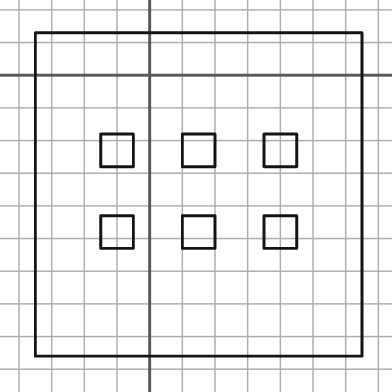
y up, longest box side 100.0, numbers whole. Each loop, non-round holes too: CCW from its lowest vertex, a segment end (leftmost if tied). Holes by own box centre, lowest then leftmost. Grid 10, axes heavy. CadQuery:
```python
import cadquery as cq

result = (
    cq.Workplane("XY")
    .moveTo(-35.0, -86.0)
    .lineTo(65.0, -86.0)
    .lineTo(65.0, 13.0)
    .lineTo(-35.0, 13.0)
    .close()
    .moveTo(-15.0, -53.0)
    .lineTo(-5.0, -53.0)
    .lineTo(-5.0, -43.0)
    .lineTo(-15.0, -43.0)
    .close()
    .moveTo(10.0, -53.0)
    .lineTo(20.0, -53.0)
    .lineTo(20.0, -43.0)
    .lineTo(10.0, -43.0)
    .close()
    .moveTo(35.0, -53.0)
    .lineTo(45.0, -53.0)
    .lineTo(45.0, -43.0)
    .lineTo(35.0, -43.0)
    .close()
    .moveTo(-15.0, -28.0)
    .lineTo(-5.0, -28.0)
    .lineTo(-5.0, -18.0)
    .lineTo(-15.0, -18.0)
    .close()
    .moveTo(10.0, -28.0)
    .lineTo(20.0, -28.0)
    .lineTo(20.0, -18.0)
    .lineTo(10.0, -18.0)
    .close()
    .moveTo(35.0, -28.0)
    .lineTo(45.0, -28.0)
    .lineTo(45.0, -18.0)
    .lineTo(35.0, -18.0)
    .close()
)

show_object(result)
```